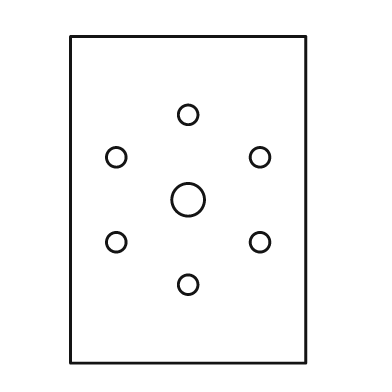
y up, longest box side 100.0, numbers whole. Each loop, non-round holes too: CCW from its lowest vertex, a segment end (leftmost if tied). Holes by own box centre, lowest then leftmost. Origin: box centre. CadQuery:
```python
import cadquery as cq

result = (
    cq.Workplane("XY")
    .moveTo(-36.0, -50.0)
    .lineTo(36.0, -50.0)
    .lineTo(36.0, 50.0)
    .lineTo(-36.0, 50.0)
    .close()
    .moveTo(0.0, -26.0)
    .circle(3.0)
    .moveTo(-22.0, -13.0)
    .circle(3.0)
    .moveTo(22.0, -13.0)
    .circle(3.0)
    .moveTo(0.0, 0.0)
    .circle(5.0)
    .moveTo(-22.0, 13.0)
    .circle(3.0)
    .moveTo(22.0, 13.0)
    .circle(3.0)
    .moveTo(0.0, 26.0)
    .circle(3.0)
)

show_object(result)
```